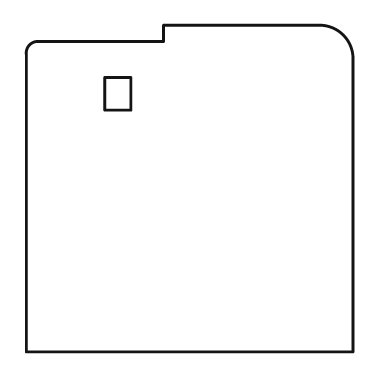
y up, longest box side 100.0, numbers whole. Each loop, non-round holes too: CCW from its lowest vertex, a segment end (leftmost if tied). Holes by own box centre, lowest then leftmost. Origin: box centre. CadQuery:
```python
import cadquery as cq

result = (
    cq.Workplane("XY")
    .moveTo(-50.0, -50.0)
    .lineTo(50.0, -50.0)
    .lineTo(50.0, 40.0)
    .threePointArc((47.0, 47.0), (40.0, 50.0))
    .lineTo(-8.0, 50.0)
    .lineTo(-8.0, 45.0)
    .lineTo(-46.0, 45.0)
    .threePointArc((-49.0, 44.0), (-50.0, 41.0))
    .close()
    .moveTo(-26.0, 24.0)
    .lineTo(-18.0, 24.0)
    .lineTo(-18.0, 34.0)
    .lineTo(-26.0, 34.0)
    .close()
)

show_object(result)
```